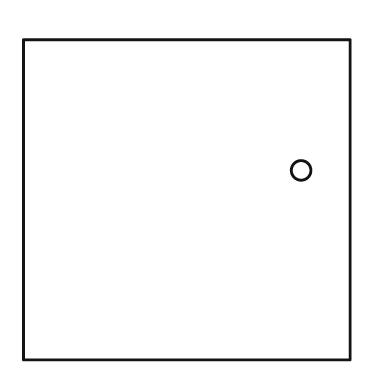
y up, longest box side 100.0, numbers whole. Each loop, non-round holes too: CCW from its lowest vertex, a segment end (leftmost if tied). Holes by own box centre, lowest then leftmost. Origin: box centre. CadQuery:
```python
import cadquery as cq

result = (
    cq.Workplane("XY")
    .moveTo(-50.0, -49.0)
    .lineTo(50.0, -49.0)
    .lineTo(50.0, 49.0)
    .lineTo(-50.0, 49.0)
    .close()
    .moveTo(35.0, 9.0)
    .circle(3.0)
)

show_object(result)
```